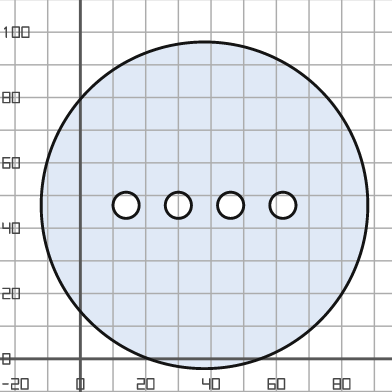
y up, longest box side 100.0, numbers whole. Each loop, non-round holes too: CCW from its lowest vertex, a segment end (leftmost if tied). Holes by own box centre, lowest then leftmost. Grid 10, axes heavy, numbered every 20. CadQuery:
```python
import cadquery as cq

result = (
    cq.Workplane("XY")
    .moveTo(38.0, 47.0)
    .circle(50.0)
    .moveTo(14.0, 47.0)
    .circle(4.0)
    .moveTo(30.0, 47.0)
    .circle(4.0)
    .moveTo(46.0, 47.0)
    .circle(4.0)
    .moveTo(62.0, 47.0)
    .circle(4.0)
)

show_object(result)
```